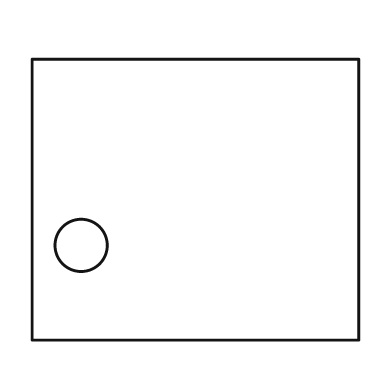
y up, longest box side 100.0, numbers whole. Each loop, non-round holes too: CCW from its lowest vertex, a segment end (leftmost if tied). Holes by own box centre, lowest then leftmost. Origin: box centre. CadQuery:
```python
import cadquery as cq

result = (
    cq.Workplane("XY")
    .moveTo(-50.0, -43.0)
    .lineTo(50.0, -43.0)
    .lineTo(50.0, 43.0)
    .lineTo(-50.0, 43.0)
    .close()
    .moveTo(-35.0, -14.0)
    .circle(8.0)
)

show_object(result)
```